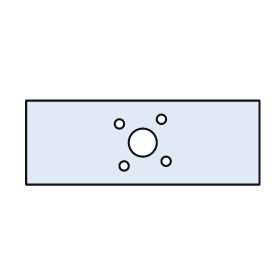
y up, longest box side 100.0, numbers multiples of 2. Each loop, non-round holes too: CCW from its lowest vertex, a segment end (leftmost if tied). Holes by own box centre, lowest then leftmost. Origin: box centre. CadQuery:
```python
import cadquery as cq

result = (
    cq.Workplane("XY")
    .moveTo(-50.0, -18.0)
    .lineTo(50.0, -18.0)
    .lineTo(50.0, 18.0)
    .lineTo(-50.0, 18.0)
    .close()
    .moveTo(-8.0, -10.0)
    .circle(2.0)
    .moveTo(10.0, -8.0)
    .circle(2.0)
    .moveTo(0.0, 0.0)
    .circle(6.0)
    .moveTo(-10.0, 8.0)
    .circle(2.0)
    .moveTo(8.0, 10.0)
    .circle(2.0)
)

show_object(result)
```